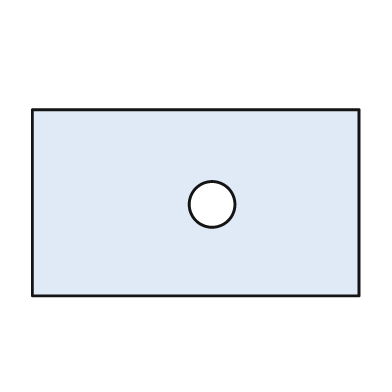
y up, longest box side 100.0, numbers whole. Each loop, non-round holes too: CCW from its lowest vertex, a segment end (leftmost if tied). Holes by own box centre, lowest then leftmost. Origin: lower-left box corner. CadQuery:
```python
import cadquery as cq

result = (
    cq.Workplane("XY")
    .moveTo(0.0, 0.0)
    .lineTo(100.0, 0.0)
    .lineTo(100.0, 57.0)
    .lineTo(0.0, 57.0)
    .close()
    .moveTo(55.0, 28.0)
    .circle(7.0)
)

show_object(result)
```